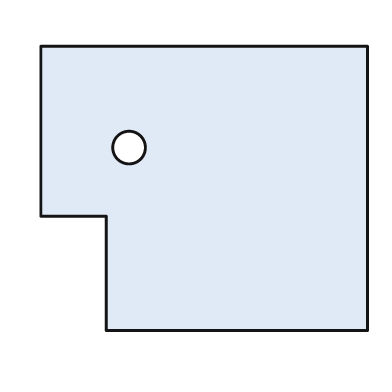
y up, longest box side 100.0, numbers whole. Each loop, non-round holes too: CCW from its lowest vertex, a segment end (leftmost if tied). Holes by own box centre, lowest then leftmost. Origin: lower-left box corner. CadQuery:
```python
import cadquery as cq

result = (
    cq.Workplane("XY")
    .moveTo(20.0, 0.0)
    .lineTo(100.0, 0.0)
    .lineTo(100.0, 87.0)
    .lineTo(0.0, 87.0)
    .lineTo(0.0, 35.0)
    .lineTo(20.0, 35.0)
    .close()
    .moveTo(27.0, 56.0)
    .circle(5.0)
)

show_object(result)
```